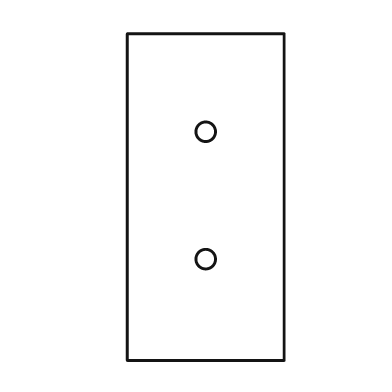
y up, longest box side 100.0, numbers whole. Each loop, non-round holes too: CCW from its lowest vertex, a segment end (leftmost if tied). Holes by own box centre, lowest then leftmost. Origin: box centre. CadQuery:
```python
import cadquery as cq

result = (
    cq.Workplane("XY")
    .moveTo(-24.0, -50.0)
    .lineTo(24.0, -50.0)
    .lineTo(24.0, 50.0)
    .lineTo(-24.0, 50.0)
    .close()
    .moveTo(0.0, -19.0)
    .circle(3.0)
    .moveTo(0.0, 20.0)
    .circle(3.0)
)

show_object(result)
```